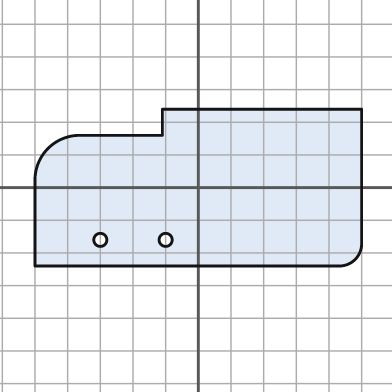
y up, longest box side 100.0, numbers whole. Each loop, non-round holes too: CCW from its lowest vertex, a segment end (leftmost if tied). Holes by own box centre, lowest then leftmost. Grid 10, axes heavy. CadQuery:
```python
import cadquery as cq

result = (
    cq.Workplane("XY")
    .moveTo(-50.0, -24.0)
    .lineTo(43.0, -24.0)
    .threePointArc((48.0, -22.0), (50.0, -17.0))
    .lineTo(50.0, 24.0)
    .lineTo(-11.0, 24.0)
    .lineTo(-11.0, 16.0)
    .lineTo(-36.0, 16.0)
    .threePointArc((-46.0, 12.0), (-50.0, 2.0))
    .close()
    .moveTo(-30.0, -16.0)
    .circle(2.0)
    .moveTo(-10.0, -16.0)
    .circle(2.0)
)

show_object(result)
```